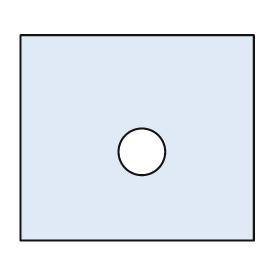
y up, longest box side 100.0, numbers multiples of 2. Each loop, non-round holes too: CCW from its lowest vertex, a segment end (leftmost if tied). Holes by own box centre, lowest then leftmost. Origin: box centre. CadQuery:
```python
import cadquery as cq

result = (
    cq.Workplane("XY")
    .moveTo(-50.0, -44.0)
    .lineTo(50.0, -44.0)
    .lineTo(50.0, 44.0)
    .lineTo(-50.0, 44.0)
    .close()
    .moveTo(2.0, -6.0)
    .circle(10.0)
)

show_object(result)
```